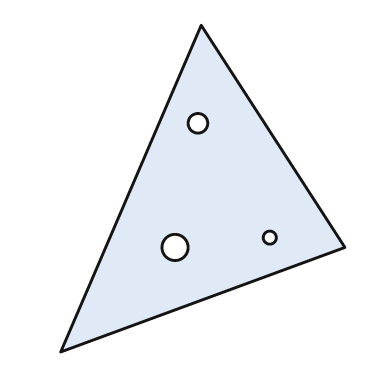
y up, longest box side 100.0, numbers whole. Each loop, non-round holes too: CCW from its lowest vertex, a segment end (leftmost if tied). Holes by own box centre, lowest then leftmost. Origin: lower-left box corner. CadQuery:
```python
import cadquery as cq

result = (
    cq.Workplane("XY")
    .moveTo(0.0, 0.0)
    .lineTo(87.0, 32.0)
    .lineTo(43.0, 100.0)
    .close()
    .moveTo(35.0, 32.0)
    .circle(4.0)
    .moveTo(64.0, 35.0)
    .circle(2.0)
    .moveTo(42.0, 70.0)
    .circle(3.0)
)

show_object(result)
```